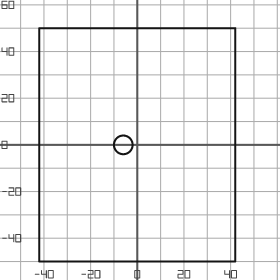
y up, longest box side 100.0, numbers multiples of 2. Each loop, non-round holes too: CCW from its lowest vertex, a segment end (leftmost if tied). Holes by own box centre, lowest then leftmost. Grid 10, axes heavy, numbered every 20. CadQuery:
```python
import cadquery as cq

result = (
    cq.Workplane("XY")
    .moveTo(-42.0, -50.0)
    .lineTo(42.0, -50.0)
    .lineTo(42.0, 50.0)
    .lineTo(-42.0, 50.0)
    .close()
    .moveTo(-6.0, 0.0)
    .circle(4.0)
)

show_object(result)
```